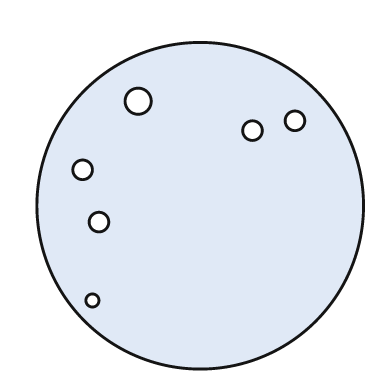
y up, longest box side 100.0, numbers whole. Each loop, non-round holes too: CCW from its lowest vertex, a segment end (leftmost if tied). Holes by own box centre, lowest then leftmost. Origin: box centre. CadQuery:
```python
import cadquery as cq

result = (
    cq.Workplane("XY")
    .moveTo(0.0, 0.0)
    .circle(50.0)
    .moveTo(-33.0, -29.0)
    .circle(2.0)
    .moveTo(-31.0, -5.0)
    .circle(3.0)
    .moveTo(-36.0, 11.0)
    .circle(3.0)
    .moveTo(16.0, 23.0)
    .circle(3.0)
    .moveTo(29.0, 26.0)
    .circle(3.0)
    .moveTo(-19.0, 32.0)
    .circle(4.0)
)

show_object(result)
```